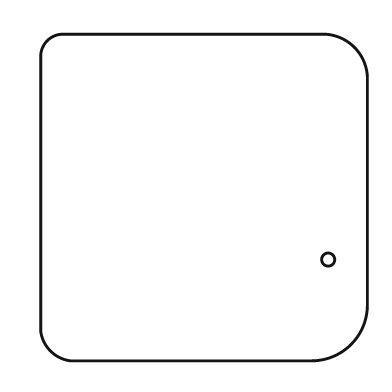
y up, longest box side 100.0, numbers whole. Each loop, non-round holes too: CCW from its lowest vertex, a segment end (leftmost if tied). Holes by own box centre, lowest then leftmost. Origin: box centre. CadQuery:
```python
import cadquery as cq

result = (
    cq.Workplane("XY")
    .moveTo(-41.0, -50.0)
    .lineTo(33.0, -50.0)
    .threePointArc((45.0, -45.0), (50.0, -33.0))
    .lineTo(50.0, 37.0)
    .threePointArc((46.0, 46.0), (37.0, 50.0))
    .lineTo(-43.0, 50.0)
    .threePointArc((-48.0, 48.0), (-50.0, 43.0))
    .lineTo(-50.0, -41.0)
    .threePointArc((-47.0, -47.0), (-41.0, -50.0))
    .close()
    .moveTo(38.0, -19.0)
    .circle(2.0)
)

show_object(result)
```